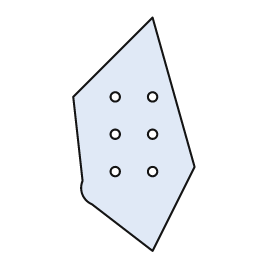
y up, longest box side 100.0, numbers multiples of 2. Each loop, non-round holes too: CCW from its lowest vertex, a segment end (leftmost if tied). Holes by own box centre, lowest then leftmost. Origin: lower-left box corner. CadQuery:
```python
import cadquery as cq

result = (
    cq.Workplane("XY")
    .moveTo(34.0, 0.0)
    .lineTo(52.0, 36.0)
    .lineTo(34.0, 100.0)
    .lineTo(0.0, 66.0)
    .lineTo(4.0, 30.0)
    .threePointArc((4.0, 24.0), (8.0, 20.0))
    .close()
    .moveTo(18.0, 34.0)
    .circle(2.0)
    .moveTo(34.0, 34.0)
    .circle(2.0)
    .moveTo(18.0, 50.0)
    .circle(2.0)
    .moveTo(34.0, 50.0)
    .circle(2.0)
    .moveTo(18.0, 66.0)
    .circle(2.0)
    .moveTo(34.0, 66.0)
    .circle(2.0)
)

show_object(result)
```